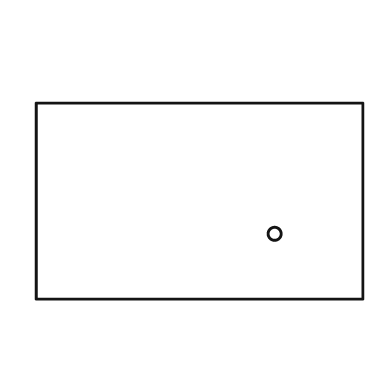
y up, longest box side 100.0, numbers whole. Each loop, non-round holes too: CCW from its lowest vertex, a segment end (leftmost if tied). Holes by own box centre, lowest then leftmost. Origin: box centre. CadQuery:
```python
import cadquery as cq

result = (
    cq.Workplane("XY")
    .moveTo(-50.0, -30.0)
    .lineTo(50.0, -30.0)
    .lineTo(50.0, 30.0)
    .lineTo(-50.0, 30.0)
    .close()
    .moveTo(23.0, -10.0)
    .circle(2.0)
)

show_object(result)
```